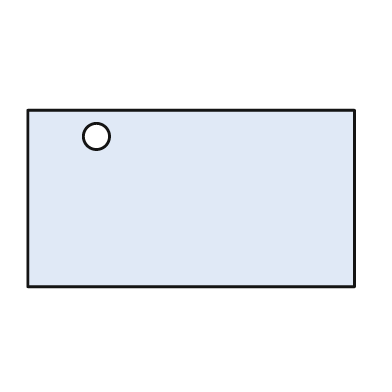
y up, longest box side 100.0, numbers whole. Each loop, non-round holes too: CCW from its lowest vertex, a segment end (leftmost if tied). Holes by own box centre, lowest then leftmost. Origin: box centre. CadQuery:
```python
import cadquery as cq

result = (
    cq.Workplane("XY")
    .moveTo(-50.0, -27.0)
    .lineTo(50.0, -27.0)
    .lineTo(50.0, 27.0)
    .lineTo(-50.0, 27.0)
    .close()
    .moveTo(-29.0, 19.0)
    .circle(4.0)
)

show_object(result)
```